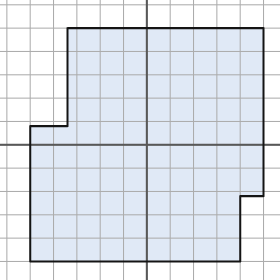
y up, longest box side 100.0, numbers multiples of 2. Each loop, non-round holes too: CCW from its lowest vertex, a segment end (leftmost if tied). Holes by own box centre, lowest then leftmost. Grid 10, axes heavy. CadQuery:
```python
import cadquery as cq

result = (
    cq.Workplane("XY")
    .moveTo(-50.0, -50.0)
    .lineTo(40.0, -50.0)
    .lineTo(40.0, -22.0)
    .lineTo(50.0, -22.0)
    .lineTo(50.0, 50.0)
    .lineTo(-34.0, 50.0)
    .lineTo(-34.0, 8.0)
    .lineTo(-50.0, 8.0)
    .close()
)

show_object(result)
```